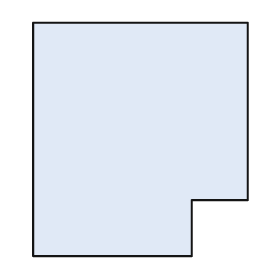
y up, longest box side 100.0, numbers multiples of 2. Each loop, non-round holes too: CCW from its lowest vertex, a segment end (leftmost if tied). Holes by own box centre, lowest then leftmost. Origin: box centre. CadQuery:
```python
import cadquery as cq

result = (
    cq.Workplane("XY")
    .moveTo(-46.0, -50.0)
    .lineTo(22.0, -50.0)
    .lineTo(22.0, -26.0)
    .lineTo(46.0, -26.0)
    .lineTo(46.0, 50.0)
    .lineTo(-46.0, 50.0)
    .close()
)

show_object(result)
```